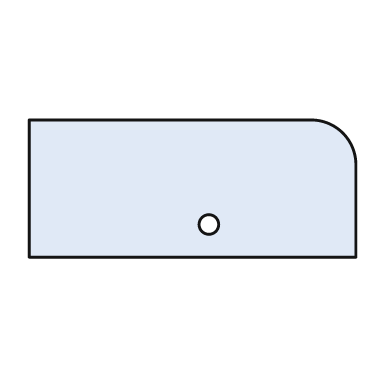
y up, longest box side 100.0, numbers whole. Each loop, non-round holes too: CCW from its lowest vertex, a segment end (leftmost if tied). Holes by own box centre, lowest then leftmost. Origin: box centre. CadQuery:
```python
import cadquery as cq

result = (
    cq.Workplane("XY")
    .moveTo(-50.0, -21.0)
    .lineTo(50.0, -21.0)
    .lineTo(50.0, 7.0)
    .threePointArc((46.0, 17.0), (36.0, 21.0))
    .lineTo(-50.0, 21.0)
    .close()
    .moveTo(5.0, -11.0)
    .circle(3.0)
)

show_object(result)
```